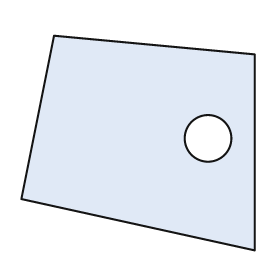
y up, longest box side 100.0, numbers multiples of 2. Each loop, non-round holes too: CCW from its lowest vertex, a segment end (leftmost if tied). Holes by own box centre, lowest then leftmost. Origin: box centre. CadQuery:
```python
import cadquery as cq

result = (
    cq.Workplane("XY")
    .moveTo(50.0, -46.0)
    .lineTo(50.0, 38.0)
    .lineTo(-36.0, 46.0)
    .lineTo(-50.0, -24.0)
    .close()
    .moveTo(30.0, 2.0)
    .circle(10.0)
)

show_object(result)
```